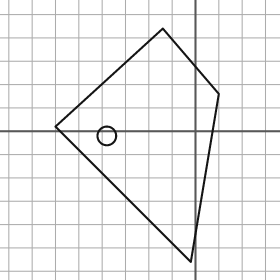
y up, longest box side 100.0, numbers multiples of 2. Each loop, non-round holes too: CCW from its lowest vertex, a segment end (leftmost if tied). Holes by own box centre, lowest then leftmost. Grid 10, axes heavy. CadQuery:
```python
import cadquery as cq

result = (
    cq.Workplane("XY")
    .moveTo(-2.0, -56.0)
    .lineTo(10.0, 16.0)
    .lineTo(-14.0, 44.0)
    .lineTo(-60.0, 2.0)
    .close()
    .moveTo(-38.0, -2.0)
    .circle(4.0)
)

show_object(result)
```